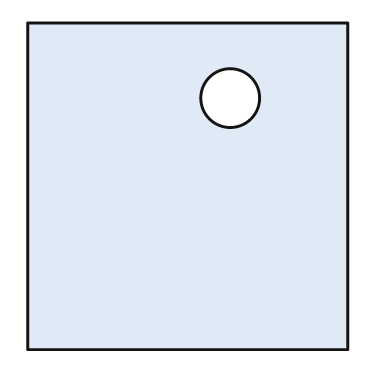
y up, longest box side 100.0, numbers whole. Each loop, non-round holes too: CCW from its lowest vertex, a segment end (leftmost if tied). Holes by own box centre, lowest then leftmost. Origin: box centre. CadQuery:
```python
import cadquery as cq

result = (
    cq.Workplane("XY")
    .moveTo(-49.0, -50.0)
    .lineTo(49.0, -50.0)
    .lineTo(49.0, 50.0)
    .lineTo(-49.0, 50.0)
    .close()
    .moveTo(13.0, 27.0)
    .circle(9.0)
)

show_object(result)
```